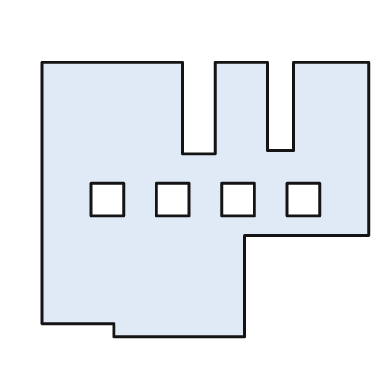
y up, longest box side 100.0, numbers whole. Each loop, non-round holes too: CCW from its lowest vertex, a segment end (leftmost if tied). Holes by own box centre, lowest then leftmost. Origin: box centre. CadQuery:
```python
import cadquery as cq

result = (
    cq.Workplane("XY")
    .moveTo(-28.0, -42.0)
    .lineTo(12.0, -42.0)
    .lineTo(12.0, -11.0)
    .lineTo(50.0, -11.0)
    .lineTo(50.0, 42.0)
    .lineTo(27.0, 42.0)
    .lineTo(27.0, 15.0)
    .lineTo(19.0, 15.0)
    .lineTo(19.0, 42.0)
    .lineTo(3.0, 42.0)
    .lineTo(3.0, 14.0)
    .lineTo(-7.0, 14.0)
    .lineTo(-7.0, 42.0)
    .lineTo(-50.0, 42.0)
    .lineTo(-50.0, -38.0)
    .lineTo(-28.0, -38.0)
    .close()
    .moveTo(-35.0, -5.0)
    .lineTo(-25.0, -5.0)
    .lineTo(-25.0, 5.0)
    .lineTo(-35.0, 5.0)
    .close()
    .moveTo(-15.0, -5.0)
    .lineTo(-5.0, -5.0)
    .lineTo(-5.0, 5.0)
    .lineTo(-15.0, 5.0)
    .close()
    .moveTo(5.0, -5.0)
    .lineTo(15.0, -5.0)
    .lineTo(15.0, 5.0)
    .lineTo(5.0, 5.0)
    .close()
    .moveTo(25.0, -5.0)
    .lineTo(35.0, -5.0)
    .lineTo(35.0, 5.0)
    .lineTo(25.0, 5.0)
    .close()
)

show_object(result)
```